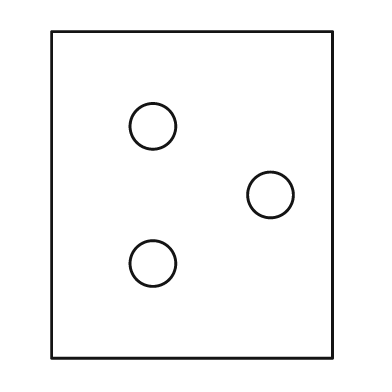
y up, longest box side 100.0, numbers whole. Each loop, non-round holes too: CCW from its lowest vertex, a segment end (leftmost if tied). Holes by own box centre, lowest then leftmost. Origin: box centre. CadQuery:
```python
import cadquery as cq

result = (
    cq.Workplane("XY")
    .moveTo(-43.0, -50.0)
    .lineTo(43.0, -50.0)
    .lineTo(43.0, 50.0)
    .lineTo(-43.0, 50.0)
    .close()
    .moveTo(-12.0, -21.0)
    .circle(7.0)
    .moveTo(24.0, 0.0)
    .circle(7.0)
    .moveTo(-12.0, 21.0)
    .circle(7.0)
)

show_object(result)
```